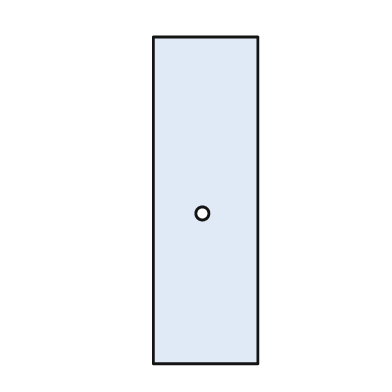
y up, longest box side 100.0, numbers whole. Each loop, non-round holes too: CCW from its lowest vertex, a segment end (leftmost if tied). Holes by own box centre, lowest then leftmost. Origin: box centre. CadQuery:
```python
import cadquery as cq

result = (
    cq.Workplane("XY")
    .moveTo(-16.0, -50.0)
    .lineTo(16.0, -50.0)
    .lineTo(16.0, 50.0)
    .lineTo(-16.0, 50.0)
    .close()
    .moveTo(-1.0, -4.0)
    .circle(2.0)
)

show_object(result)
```